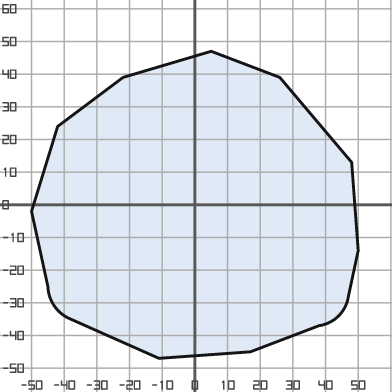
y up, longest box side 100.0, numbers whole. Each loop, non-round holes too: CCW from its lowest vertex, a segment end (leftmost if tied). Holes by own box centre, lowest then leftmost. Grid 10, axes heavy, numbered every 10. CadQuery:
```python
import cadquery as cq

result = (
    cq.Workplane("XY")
    .moveTo(-11.0, -47.0)
    .lineTo(17.0, -45.0)
    .lineTo(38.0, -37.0)
    .threePointArc((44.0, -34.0), (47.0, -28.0))
    .lineTo(50.0, -14.0)
    .lineTo(48.0, 13.0)
    .lineTo(26.0, 39.0)
    .lineTo(5.0, 47.0)
    .lineTo(-22.0, 39.0)
    .lineTo(-42.0, 24.0)
    .lineTo(-50.0, -2.0)
    .lineTo(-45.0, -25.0)
    .threePointArc((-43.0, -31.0), (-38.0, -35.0))
    .close()
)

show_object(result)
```